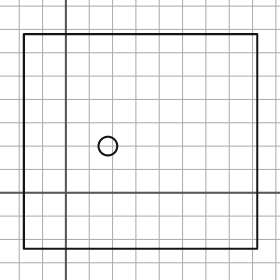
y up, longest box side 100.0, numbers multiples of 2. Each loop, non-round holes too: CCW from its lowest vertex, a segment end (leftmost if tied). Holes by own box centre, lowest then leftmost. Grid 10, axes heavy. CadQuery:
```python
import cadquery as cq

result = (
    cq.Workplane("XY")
    .moveTo(-18.0, -24.0)
    .lineTo(82.0, -24.0)
    .lineTo(82.0, 68.0)
    .lineTo(-18.0, 68.0)
    .close()
    .moveTo(18.0, 20.0)
    .circle(4.0)
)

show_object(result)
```